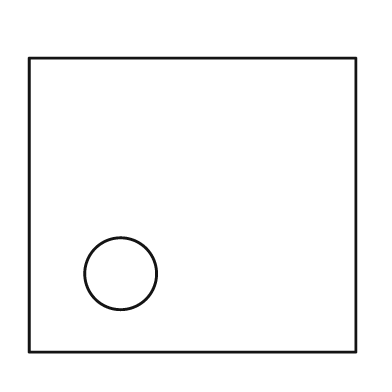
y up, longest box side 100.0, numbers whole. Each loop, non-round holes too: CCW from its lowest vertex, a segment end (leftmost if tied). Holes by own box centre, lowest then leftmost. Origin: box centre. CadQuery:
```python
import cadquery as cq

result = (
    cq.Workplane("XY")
    .moveTo(-50.0, -45.0)
    .lineTo(50.0, -45.0)
    .lineTo(50.0, 45.0)
    .lineTo(-50.0, 45.0)
    .close()
    .moveTo(-22.0, -21.0)
    .circle(11.0)
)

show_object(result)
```